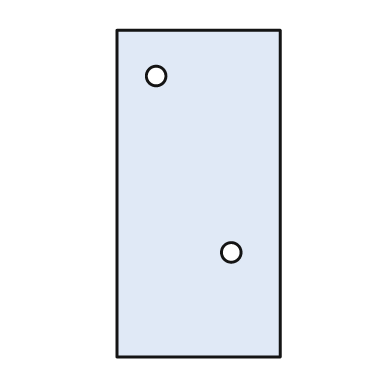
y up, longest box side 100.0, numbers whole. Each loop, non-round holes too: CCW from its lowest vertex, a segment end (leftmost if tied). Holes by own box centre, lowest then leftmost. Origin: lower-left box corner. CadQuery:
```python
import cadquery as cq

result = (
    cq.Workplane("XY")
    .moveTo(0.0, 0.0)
    .lineTo(50.0, 0.0)
    .lineTo(50.0, 100.0)
    .lineTo(0.0, 100.0)
    .close()
    .moveTo(35.0, 32.0)
    .circle(3.0)
    .moveTo(12.0, 86.0)
    .circle(3.0)
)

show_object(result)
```